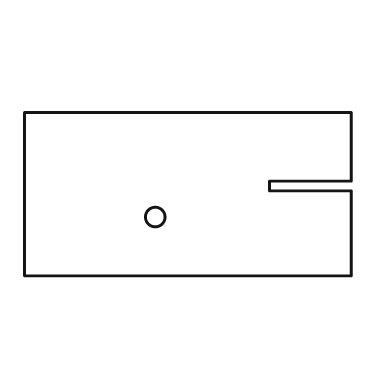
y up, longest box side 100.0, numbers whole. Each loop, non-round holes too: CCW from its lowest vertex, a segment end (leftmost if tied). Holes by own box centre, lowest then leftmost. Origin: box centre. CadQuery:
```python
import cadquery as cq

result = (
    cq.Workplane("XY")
    .moveTo(-50.0, -25.0)
    .lineTo(50.0, -25.0)
    .lineTo(50.0, 1.0)
    .lineTo(25.0, 1.0)
    .lineTo(25.0, 4.0)
    .lineTo(50.0, 4.0)
    .lineTo(50.0, 25.0)
    .lineTo(-50.0, 25.0)
    .close()
    .moveTo(-10.0, -7.0)
    .circle(3.0)
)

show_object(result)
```